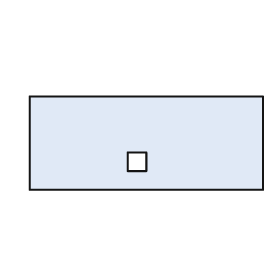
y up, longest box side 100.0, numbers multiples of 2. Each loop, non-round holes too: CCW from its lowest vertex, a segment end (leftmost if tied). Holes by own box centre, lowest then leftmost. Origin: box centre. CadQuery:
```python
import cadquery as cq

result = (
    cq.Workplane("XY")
    .moveTo(-50.0, -20.0)
    .lineTo(50.0, -20.0)
    .lineTo(50.0, 20.0)
    .lineTo(-50.0, 20.0)
    .close()
    .moveTo(-8.0, -12.0)
    .lineTo(0.0, -12.0)
    .lineTo(0.0, -4.0)
    .lineTo(-8.0, -4.0)
    .close()
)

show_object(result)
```